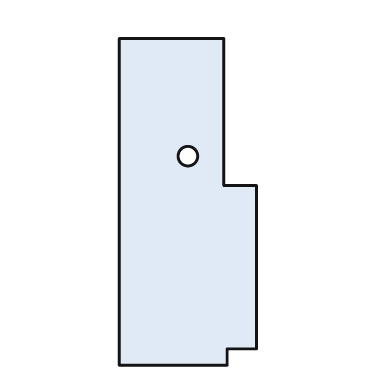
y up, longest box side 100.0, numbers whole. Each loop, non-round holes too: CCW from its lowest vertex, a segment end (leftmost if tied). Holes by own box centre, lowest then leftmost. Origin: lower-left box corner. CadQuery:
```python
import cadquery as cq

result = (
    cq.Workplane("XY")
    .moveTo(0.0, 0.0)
    .lineTo(33.0, 0.0)
    .lineTo(33.0, 5.0)
    .lineTo(42.0, 5.0)
    .lineTo(42.0, 55.0)
    .lineTo(32.0, 55.0)
    .lineTo(32.0, 100.0)
    .lineTo(0.0, 100.0)
    .close()
    .moveTo(21.0, 64.0)
    .circle(3.0)
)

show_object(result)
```